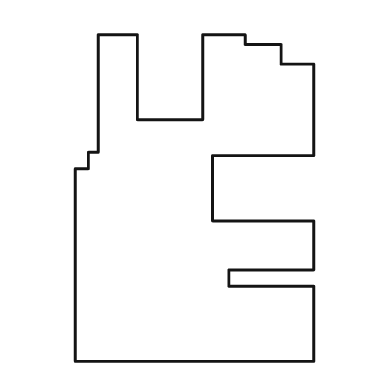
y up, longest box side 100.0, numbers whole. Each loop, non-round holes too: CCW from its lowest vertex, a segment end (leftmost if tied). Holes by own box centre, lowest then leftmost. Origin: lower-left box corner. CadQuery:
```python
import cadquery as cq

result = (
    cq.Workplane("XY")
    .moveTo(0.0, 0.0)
    .lineTo(73.0, 0.0)
    .lineTo(73.0, 23.0)
    .lineTo(47.0, 23.0)
    .lineTo(47.0, 28.0)
    .lineTo(73.0, 28.0)
    .lineTo(73.0, 43.0)
    .lineTo(42.0, 43.0)
    .lineTo(42.0, 63.0)
    .lineTo(73.0, 63.0)
    .lineTo(73.0, 91.0)
    .lineTo(63.0, 91.0)
    .lineTo(63.0, 97.0)
    .lineTo(52.0, 97.0)
    .lineTo(52.0, 100.0)
    .lineTo(39.0, 100.0)
    .lineTo(39.0, 74.0)
    .lineTo(19.0, 74.0)
    .lineTo(19.0, 100.0)
    .lineTo(7.0, 100.0)
    .lineTo(7.0, 64.0)
    .lineTo(4.0, 64.0)
    .lineTo(4.0, 59.0)
    .lineTo(0.0, 59.0)
    .close()
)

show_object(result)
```